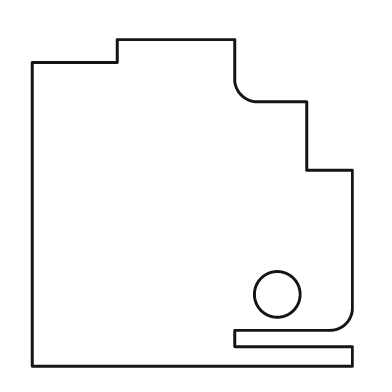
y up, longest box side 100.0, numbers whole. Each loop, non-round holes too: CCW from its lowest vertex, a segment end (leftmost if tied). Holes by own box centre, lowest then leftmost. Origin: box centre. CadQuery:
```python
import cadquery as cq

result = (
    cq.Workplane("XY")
    .moveTo(-49.0, -50.0)
    .lineTo(49.0, -50.0)
    .lineTo(49.0, -44.0)
    .lineTo(13.0, -44.0)
    .lineTo(13.0, -39.0)
    .lineTo(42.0, -39.0)
    .threePointArc((47.0, -37.0), (49.0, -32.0))
    .lineTo(49.0, 10.0)
    .lineTo(35.0, 10.0)
    .lineTo(35.0, 31.0)
    .lineTo(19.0, 31.0)
    .threePointArc((15.0, 33.0), (13.0, 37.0))
    .lineTo(13.0, 50.0)
    .lineTo(-23.0, 50.0)
    .lineTo(-23.0, 43.0)
    .lineTo(-49.0, 43.0)
    .close()
    .moveTo(26.0, -28.0)
    .circle(7.0)
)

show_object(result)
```